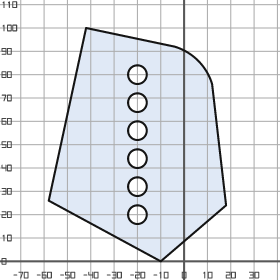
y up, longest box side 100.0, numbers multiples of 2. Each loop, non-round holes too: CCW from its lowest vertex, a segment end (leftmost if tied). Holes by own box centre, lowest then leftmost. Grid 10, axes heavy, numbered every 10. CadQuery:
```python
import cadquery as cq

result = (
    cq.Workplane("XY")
    .moveTo(-10.0, 0.0)
    .lineTo(18.0, 24.0)
    .lineTo(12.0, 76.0)
    .threePointArc((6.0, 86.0), (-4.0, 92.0))
    .lineTo(-42.0, 100.0)
    .lineTo(-58.0, 26.0)
    .close()
    .moveTo(-20.0, 20.0)
    .circle(4.0)
    .moveTo(-20.0, 32.0)
    .circle(4.0)
    .moveTo(-20.0, 44.0)
    .circle(4.0)
    .moveTo(-20.0, 56.0)
    .circle(4.0)
    .moveTo(-20.0, 68.0)
    .circle(4.0)
    .moveTo(-20.0, 80.0)
    .circle(4.0)
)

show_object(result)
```